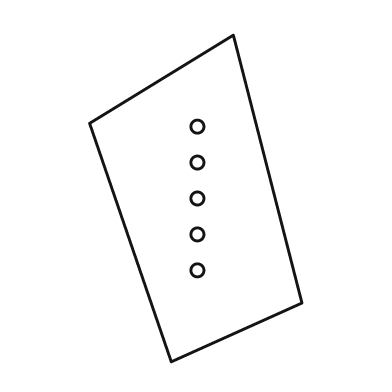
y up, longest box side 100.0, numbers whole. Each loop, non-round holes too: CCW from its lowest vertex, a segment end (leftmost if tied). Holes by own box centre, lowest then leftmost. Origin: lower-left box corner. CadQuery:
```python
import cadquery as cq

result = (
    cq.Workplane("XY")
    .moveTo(25.0, 0.0)
    .lineTo(65.0, 18.0)
    .lineTo(44.0, 100.0)
    .lineTo(0.0, 73.0)
    .close()
    .moveTo(33.0, 28.0)
    .circle(2.0)
    .moveTo(33.0, 39.0)
    .circle(2.0)
    .moveTo(33.0, 50.0)
    .circle(2.0)
    .moveTo(33.0, 61.0)
    .circle(2.0)
    .moveTo(33.0, 72.0)
    .circle(2.0)
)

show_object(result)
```